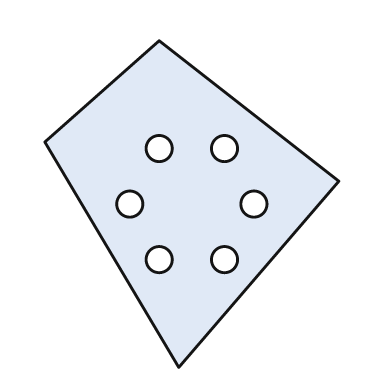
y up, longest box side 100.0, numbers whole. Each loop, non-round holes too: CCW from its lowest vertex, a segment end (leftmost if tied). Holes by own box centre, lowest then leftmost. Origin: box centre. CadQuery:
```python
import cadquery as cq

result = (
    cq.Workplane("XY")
    .moveTo(-4.0, -50.0)
    .lineTo(45.0, 7.0)
    .lineTo(-10.0, 50.0)
    .lineTo(-45.0, 19.0)
    .close()
    .moveTo(-10.0, -17.0)
    .circle(4.0)
    .moveTo(10.0, -17.0)
    .circle(4.0)
    .moveTo(-19.0, 0.0)
    .circle(4.0)
    .moveTo(19.0, 0.0)
    .circle(4.0)
    .moveTo(-10.0, 17.0)
    .circle(4.0)
    .moveTo(10.0, 17.0)
    .circle(4.0)
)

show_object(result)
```